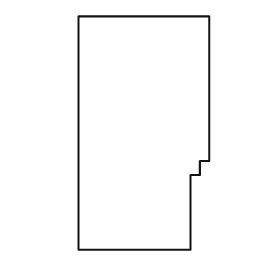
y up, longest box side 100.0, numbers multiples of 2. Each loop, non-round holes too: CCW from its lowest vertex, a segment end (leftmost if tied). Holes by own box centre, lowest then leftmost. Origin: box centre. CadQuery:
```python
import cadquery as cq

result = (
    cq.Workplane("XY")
    .moveTo(-28.0, -50.0)
    .lineTo(20.0, -50.0)
    .lineTo(20.0, -18.0)
    .lineTo(24.0, -18.0)
    .lineTo(24.0, -12.0)
    .lineTo(28.0, -12.0)
    .lineTo(28.0, 50.0)
    .lineTo(-28.0, 50.0)
    .close()
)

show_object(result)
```